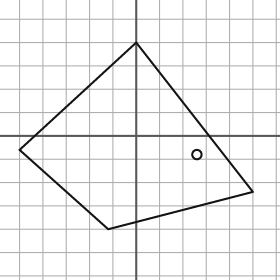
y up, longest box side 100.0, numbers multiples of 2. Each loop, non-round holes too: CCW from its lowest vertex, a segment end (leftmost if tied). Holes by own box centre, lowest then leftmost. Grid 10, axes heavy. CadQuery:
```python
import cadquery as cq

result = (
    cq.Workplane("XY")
    .moveTo(-12.0, -40.0)
    .lineTo(50.0, -24.0)
    .lineTo(0.0, 40.0)
    .lineTo(-50.0, -6.0)
    .close()
    .moveTo(26.0, -8.0)
    .circle(2.0)
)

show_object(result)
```